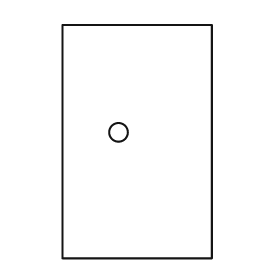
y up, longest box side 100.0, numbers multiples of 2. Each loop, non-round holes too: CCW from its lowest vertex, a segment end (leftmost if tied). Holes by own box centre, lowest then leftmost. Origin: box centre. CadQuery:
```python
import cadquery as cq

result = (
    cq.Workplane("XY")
    .moveTo(-32.0, -50.0)
    .lineTo(32.0, -50.0)
    .lineTo(32.0, 50.0)
    .lineTo(-32.0, 50.0)
    .close()
    .moveTo(-8.0, 4.0)
    .circle(4.0)
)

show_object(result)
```